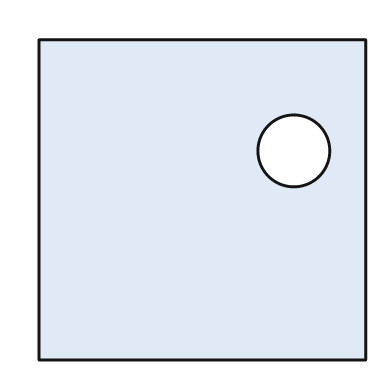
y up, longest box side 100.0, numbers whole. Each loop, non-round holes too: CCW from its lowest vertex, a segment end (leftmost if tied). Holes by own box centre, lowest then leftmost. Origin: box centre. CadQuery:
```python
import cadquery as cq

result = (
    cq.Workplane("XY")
    .moveTo(-50.0, -49.0)
    .lineTo(50.0, -49.0)
    .lineTo(50.0, 49.0)
    .lineTo(-50.0, 49.0)
    .close()
    .moveTo(28.0, 15.0)
    .circle(11.0)
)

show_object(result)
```